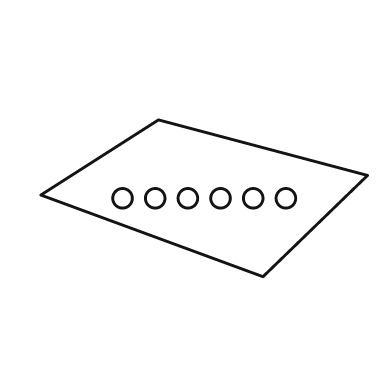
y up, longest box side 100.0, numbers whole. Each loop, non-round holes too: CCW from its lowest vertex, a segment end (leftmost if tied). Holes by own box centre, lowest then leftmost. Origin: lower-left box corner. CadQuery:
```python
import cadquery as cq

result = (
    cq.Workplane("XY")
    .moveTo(68.0, 0.0)
    .lineTo(100.0, 31.0)
    .lineTo(36.0, 48.0)
    .lineTo(0.0, 25.0)
    .close()
    .moveTo(25.0, 24.0)
    .circle(3.0)
    .moveTo(35.0, 24.0)
    .circle(3.0)
    .moveTo(45.0, 24.0)
    .circle(3.0)
    .moveTo(55.0, 24.0)
    .circle(3.0)
    .moveTo(65.0, 24.0)
    .circle(3.0)
    .moveTo(75.0, 24.0)
    .circle(3.0)
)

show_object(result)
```